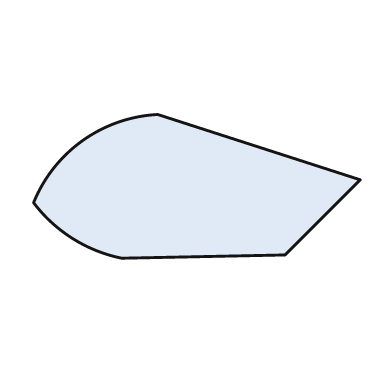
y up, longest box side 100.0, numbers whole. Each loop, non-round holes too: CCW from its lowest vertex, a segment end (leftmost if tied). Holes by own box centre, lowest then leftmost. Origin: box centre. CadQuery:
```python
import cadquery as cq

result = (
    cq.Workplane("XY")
    .moveTo(-23.0, -22.0)
    .lineTo(27.0, -21.0)
    .lineTo(50.0, 2.0)
    .lineTo(-12.0, 22.0)
    .threePointArc((-35.0, 14.0), (-50.0, -5.0))
    .threePointArc((-38.0, -16.0), (-23.0, -22.0))
    .close()
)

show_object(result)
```